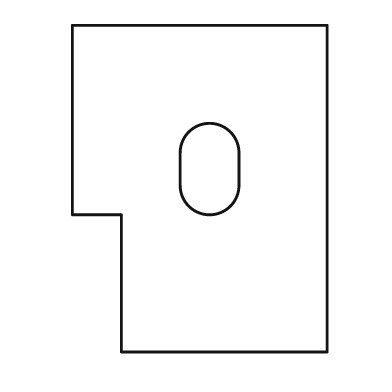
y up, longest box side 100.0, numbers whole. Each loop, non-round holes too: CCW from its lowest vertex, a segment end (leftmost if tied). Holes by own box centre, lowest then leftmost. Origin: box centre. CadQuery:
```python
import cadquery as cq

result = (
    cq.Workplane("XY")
    .moveTo(-24.0, -50.0)
    .lineTo(39.0, -50.0)
    .lineTo(39.0, 50.0)
    .lineTo(-39.0, 50.0)
    .lineTo(-39.0, -8.0)
    .lineTo(-24.0, -8.0)
    .close()
    .moveTo(-6.0, 1.0)
    .threePointArc((3.0, -8.0), (12.0, 1.0))
    .lineTo(12.0, 11.0)
    .threePointArc((3.0, 20.0), (-6.0, 11.0))
    .close()
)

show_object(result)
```